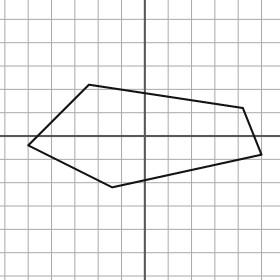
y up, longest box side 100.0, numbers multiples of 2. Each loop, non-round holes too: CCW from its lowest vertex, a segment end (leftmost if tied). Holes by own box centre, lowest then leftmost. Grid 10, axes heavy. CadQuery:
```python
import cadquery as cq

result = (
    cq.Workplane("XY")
    .moveTo(-14.0, -22.0)
    .lineTo(50.0, -8.0)
    .lineTo(42.0, 12.0)
    .lineTo(-24.0, 22.0)
    .lineTo(-50.0, -4.0)
    .close()
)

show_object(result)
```